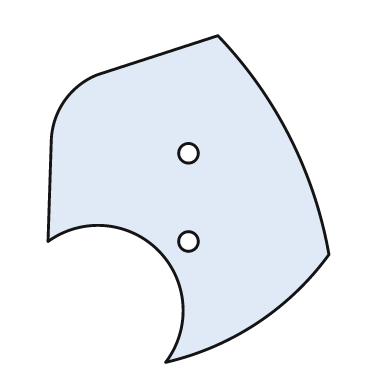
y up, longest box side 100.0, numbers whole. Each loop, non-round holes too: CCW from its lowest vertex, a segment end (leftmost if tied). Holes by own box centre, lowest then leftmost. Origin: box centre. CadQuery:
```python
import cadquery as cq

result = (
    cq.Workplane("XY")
    .moveTo(-7.0, -50.0)
    .threePointArc((21.0, -38.0), (43.0, -17.0))
    .threePointArc((31.0, 19.0), (9.0, 50.0))
    .lineTo(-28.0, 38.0)
    .threePointArc((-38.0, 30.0), (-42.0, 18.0))
    .lineTo(-43.0, -13.0)
    .threePointArc((-9.0, -16.0), (-7.0, -50.0))
    .close()
    .moveTo(0.0, -13.0)
    .circle(3.0)
    .moveTo(0.0, 14.0)
    .circle(3.0)
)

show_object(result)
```